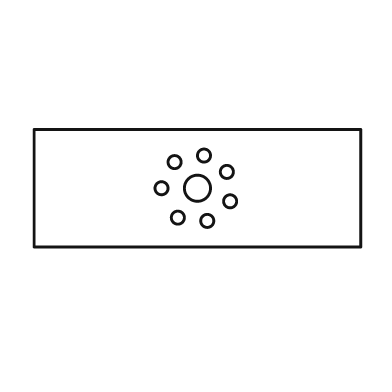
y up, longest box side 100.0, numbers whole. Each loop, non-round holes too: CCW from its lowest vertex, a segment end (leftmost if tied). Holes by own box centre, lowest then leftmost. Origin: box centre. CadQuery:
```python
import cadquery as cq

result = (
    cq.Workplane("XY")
    .moveTo(-50.0, -18.0)
    .lineTo(50.0, -18.0)
    .lineTo(50.0, 18.0)
    .lineTo(-50.0, 18.0)
    .close()
    .moveTo(3.0, -10.0)
    .circle(2.0)
    .moveTo(-6.0, -9.0)
    .circle(2.0)
    .moveTo(10.0, -4.0)
    .circle(2.0)
    .moveTo(-11.0, 0.0)
    .circle(2.0)
    .moveTo(0.0, 0.0)
    .circle(4.0)
    .moveTo(9.0, 5.0)
    .circle(2.0)
    .moveTo(-7.0, 8.0)
    .circle(2.0)
    .moveTo(2.0, 10.0)
    .circle(2.0)
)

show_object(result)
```